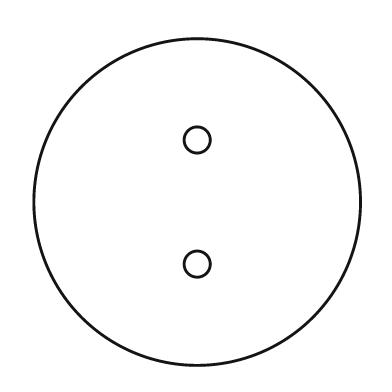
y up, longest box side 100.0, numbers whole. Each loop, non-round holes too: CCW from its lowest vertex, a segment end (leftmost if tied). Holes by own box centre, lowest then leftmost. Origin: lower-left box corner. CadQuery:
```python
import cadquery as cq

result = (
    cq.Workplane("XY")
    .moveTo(50.0, 50.0)
    .circle(50.0)
    .moveTo(50.0, 31.0)
    .circle(4.0)
    .moveTo(50.0, 69.0)
    .circle(4.0)
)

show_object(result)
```